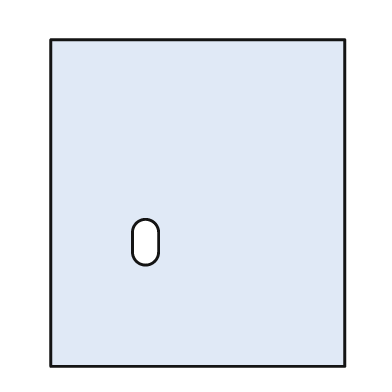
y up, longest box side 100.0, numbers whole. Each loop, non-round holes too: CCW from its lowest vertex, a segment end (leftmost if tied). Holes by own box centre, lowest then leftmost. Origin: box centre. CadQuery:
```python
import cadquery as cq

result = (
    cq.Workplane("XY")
    .moveTo(-45.0, -50.0)
    .lineTo(45.0, -50.0)
    .lineTo(45.0, 50.0)
    .lineTo(-45.0, 50.0)
    .close()
    .moveTo(-20.0, -15.0)
    .threePointArc((-16.0, -19.0), (-12.0, -15.0))
    .lineTo(-12.0, -9.0)
    .threePointArc((-16.0, -5.0), (-20.0, -9.0))
    .close()
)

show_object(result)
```